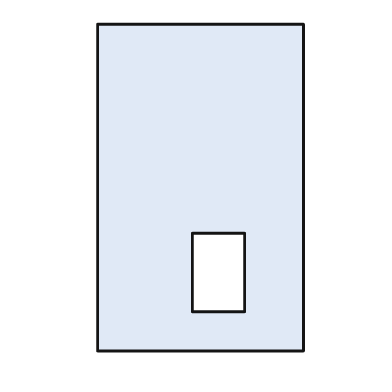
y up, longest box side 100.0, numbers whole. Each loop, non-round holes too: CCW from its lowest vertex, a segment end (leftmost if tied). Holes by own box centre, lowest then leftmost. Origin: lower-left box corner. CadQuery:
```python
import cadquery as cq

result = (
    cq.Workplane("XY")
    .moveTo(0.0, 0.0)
    .lineTo(63.0, 0.0)
    .lineTo(63.0, 100.0)
    .lineTo(0.0, 100.0)
    .close()
    .moveTo(29.0, 12.0)
    .lineTo(45.0, 12.0)
    .lineTo(45.0, 36.0)
    .lineTo(29.0, 36.0)
    .close()
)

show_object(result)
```